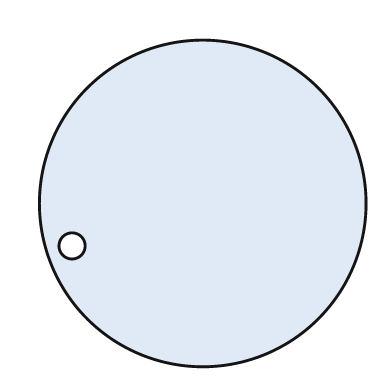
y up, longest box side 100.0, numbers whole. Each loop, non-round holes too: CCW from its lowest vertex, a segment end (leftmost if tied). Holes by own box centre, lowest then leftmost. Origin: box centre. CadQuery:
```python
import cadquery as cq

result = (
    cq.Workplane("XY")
    .moveTo(0.0, 0.0)
    .circle(50.0)
    .moveTo(-40.0, -13.0)
    .circle(4.0)
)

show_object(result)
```